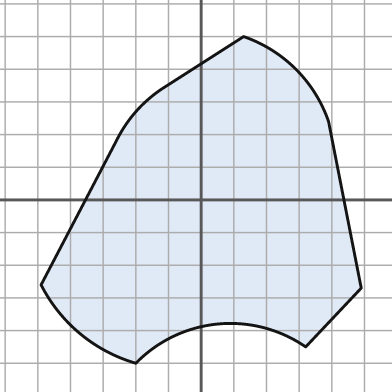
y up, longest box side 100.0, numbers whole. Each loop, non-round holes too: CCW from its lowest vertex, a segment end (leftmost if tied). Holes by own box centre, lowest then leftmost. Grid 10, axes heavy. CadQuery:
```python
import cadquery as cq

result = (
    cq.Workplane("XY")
    .moveTo(-20.0, -50.0)
    .threePointArc((5.0, -38.0), (32.0, -45.0))
    .lineTo(49.0, -27.0)
    .lineTo(39.0, 24.0)
    .threePointArc((29.0, 40.0), (13.0, 50.0))
    .lineTo(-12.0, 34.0)
    .threePointArc((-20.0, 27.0), (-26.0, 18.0))
    .lineTo(-49.0, -26.0)
    .threePointArc((-37.0, -41.0), (-20.0, -50.0))
    .close()
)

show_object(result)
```